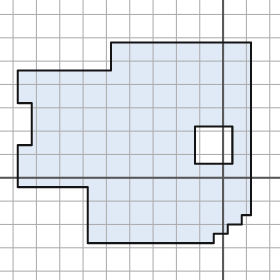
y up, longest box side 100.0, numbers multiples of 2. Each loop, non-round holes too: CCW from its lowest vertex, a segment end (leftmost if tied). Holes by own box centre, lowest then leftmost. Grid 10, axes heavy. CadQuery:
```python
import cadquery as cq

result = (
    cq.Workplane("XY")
    .moveTo(-58.0, -28.0)
    .lineTo(-4.0, -28.0)
    .lineTo(-4.0, -24.0)
    .lineTo(2.0, -24.0)
    .lineTo(2.0, -20.0)
    .lineTo(8.0, -20.0)
    .lineTo(8.0, -16.0)
    .lineTo(12.0, -16.0)
    .lineTo(12.0, 58.0)
    .lineTo(-48.0, 58.0)
    .lineTo(-48.0, 46.0)
    .lineTo(-88.0, 46.0)
    .lineTo(-88.0, 32.0)
    .lineTo(-82.0, 32.0)
    .lineTo(-82.0, 14.0)
    .lineTo(-88.0, 14.0)
    .lineTo(-88.0, -4.0)
    .lineTo(-58.0, -4.0)
    .close()
    .moveTo(-12.0, 6.0)
    .lineTo(4.0, 6.0)
    .lineTo(4.0, 22.0)
    .lineTo(-12.0, 22.0)
    .close()
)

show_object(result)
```